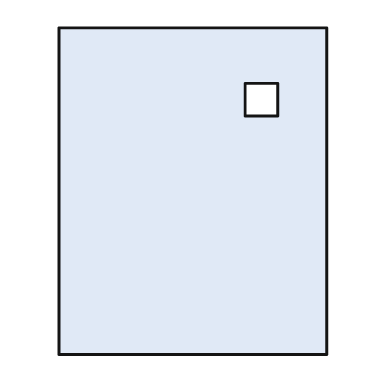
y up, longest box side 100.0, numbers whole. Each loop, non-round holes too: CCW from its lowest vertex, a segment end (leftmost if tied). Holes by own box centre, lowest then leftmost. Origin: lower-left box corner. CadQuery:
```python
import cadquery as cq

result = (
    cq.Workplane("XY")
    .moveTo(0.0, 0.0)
    .lineTo(82.0, 0.0)
    .lineTo(82.0, 100.0)
    .lineTo(0.0, 100.0)
    .close()
    .moveTo(57.0, 73.0)
    .lineTo(67.0, 73.0)
    .lineTo(67.0, 83.0)
    .lineTo(57.0, 83.0)
    .close()
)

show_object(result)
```